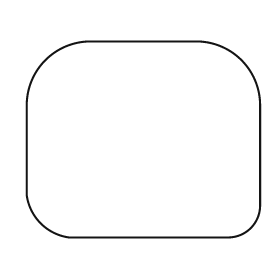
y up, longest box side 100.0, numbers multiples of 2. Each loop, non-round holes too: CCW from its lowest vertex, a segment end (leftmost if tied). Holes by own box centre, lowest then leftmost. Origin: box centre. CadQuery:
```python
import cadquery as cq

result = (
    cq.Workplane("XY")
    .moveTo(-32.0, -42.0)
    .lineTo(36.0, -42.0)
    .threePointArc((46.0, -38.0), (50.0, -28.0))
    .lineTo(50.0, 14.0)
    .threePointArc((42.0, 34.0), (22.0, 42.0))
    .lineTo(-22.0, 42.0)
    .threePointArc((-42.0, 34.0), (-50.0, 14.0))
    .lineTo(-50.0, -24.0)
    .threePointArc((-44.0, -36.0), (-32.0, -42.0))
    .close()
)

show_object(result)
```